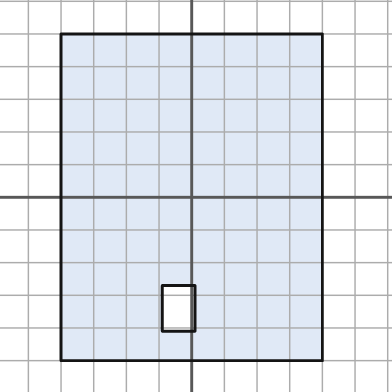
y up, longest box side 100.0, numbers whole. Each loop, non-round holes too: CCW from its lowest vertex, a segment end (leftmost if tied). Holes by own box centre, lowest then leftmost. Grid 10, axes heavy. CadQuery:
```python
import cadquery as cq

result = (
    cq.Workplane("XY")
    .moveTo(-40.0, -50.0)
    .lineTo(40.0, -50.0)
    .lineTo(40.0, 50.0)
    .lineTo(-40.0, 50.0)
    .close()
    .moveTo(-9.0, -41.0)
    .lineTo(1.0, -41.0)
    .lineTo(1.0, -27.0)
    .lineTo(-9.0, -27.0)
    .close()
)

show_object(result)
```